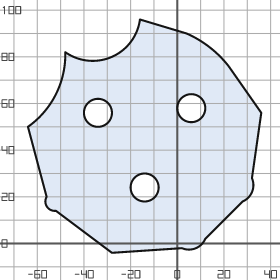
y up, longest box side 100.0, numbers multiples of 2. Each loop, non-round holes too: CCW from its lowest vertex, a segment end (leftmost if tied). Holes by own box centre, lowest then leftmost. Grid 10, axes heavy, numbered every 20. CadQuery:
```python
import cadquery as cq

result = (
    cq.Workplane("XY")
    .moveTo(-28.0, -4.0)
    .lineTo(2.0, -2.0)
    .threePointArc((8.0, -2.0), (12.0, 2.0))
    .lineTo(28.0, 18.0)
    .threePointArc((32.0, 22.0), (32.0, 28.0))
    .lineTo(36.0, 56.0)
    .lineTo(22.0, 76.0)
    .threePointArc((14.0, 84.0), (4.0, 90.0))
    .lineTo(-16.0, 96.0)
    .threePointArc((-28.0, 80.0), (-48.0, 82.0))
    .threePointArc((-52.0, 64.0), (-64.0, 50.0))
    .lineTo(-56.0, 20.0)
    .threePointArc((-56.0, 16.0), (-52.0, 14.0))
    .close()
    .moveTo(-14.0, 24.0)
    .circle(6.0)
    .moveTo(-34.0, 56.0)
    .circle(6.0)
    .moveTo(6.0, 58.0)
    .circle(6.0)
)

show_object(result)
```